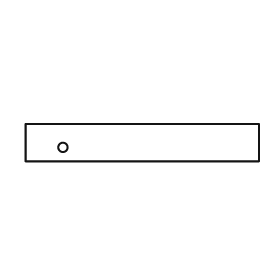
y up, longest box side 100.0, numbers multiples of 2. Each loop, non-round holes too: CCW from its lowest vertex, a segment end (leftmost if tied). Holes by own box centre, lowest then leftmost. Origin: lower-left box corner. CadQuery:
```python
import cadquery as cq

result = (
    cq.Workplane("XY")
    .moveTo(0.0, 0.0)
    .lineTo(100.0, 0.0)
    .lineTo(100.0, 16.0)
    .lineTo(0.0, 16.0)
    .close()
    .moveTo(16.0, 6.0)
    .circle(2.0)
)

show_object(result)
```